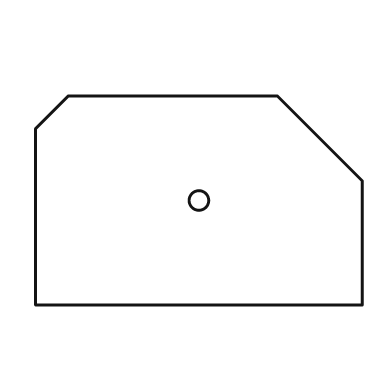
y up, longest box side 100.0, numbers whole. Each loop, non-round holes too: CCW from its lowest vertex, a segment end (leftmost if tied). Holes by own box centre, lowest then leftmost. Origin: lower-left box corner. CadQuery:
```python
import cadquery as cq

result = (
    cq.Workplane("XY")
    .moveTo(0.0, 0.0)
    .lineTo(100.0, 0.0)
    .lineTo(100.0, 38.0)
    .lineTo(74.0, 64.0)
    .lineTo(10.0, 64.0)
    .lineTo(0.0, 54.0)
    .close()
    .moveTo(50.0, 32.0)
    .circle(3.0)
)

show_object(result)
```